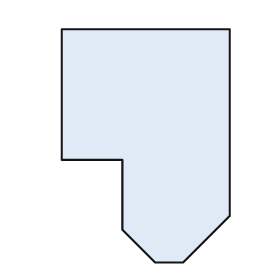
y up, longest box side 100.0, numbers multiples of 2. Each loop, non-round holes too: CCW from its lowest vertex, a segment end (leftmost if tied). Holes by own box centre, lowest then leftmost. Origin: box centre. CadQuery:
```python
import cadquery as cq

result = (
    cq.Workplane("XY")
    .moveTo(4.0, -50.0)
    .lineTo(16.0, -50.0)
    .lineTo(36.0, -30.0)
    .lineTo(36.0, 50.0)
    .lineTo(-36.0, 50.0)
    .lineTo(-36.0, -6.0)
    .lineTo(-10.0, -6.0)
    .lineTo(-10.0, -36.0)
    .close()
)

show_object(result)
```